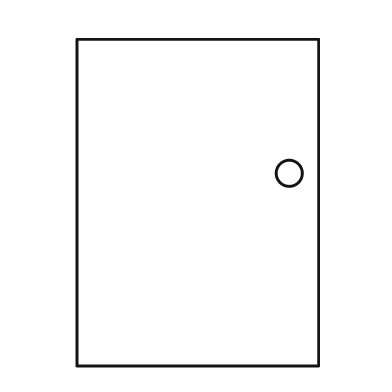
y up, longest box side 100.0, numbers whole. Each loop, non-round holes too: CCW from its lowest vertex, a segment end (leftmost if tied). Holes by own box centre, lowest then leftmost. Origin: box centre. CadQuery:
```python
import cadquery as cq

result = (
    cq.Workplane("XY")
    .moveTo(-37.0, -50.0)
    .lineTo(37.0, -50.0)
    .lineTo(37.0, 50.0)
    .lineTo(-37.0, 50.0)
    .close()
    .moveTo(28.0, 9.0)
    .circle(4.0)
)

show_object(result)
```